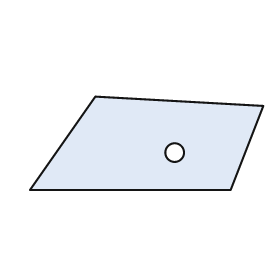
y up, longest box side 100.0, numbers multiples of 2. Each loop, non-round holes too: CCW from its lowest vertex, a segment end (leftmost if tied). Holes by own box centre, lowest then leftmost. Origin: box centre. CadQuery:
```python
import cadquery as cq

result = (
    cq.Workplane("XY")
    .moveTo(-50.0, -20.0)
    .lineTo(36.0, -20.0)
    .lineTo(50.0, 16.0)
    .lineTo(-22.0, 20.0)
    .close()
    .moveTo(12.0, -4.0)
    .circle(4.0)
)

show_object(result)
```